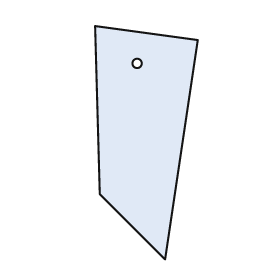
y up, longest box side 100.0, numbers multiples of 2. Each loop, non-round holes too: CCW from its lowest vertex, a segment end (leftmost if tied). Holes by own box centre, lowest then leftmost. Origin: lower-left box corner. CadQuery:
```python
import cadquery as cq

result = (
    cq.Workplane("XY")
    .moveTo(30.0, 0.0)
    .lineTo(44.0, 94.0)
    .lineTo(0.0, 100.0)
    .lineTo(2.0, 28.0)
    .close()
    .moveTo(18.0, 84.0)
    .circle(2.0)
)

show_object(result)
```